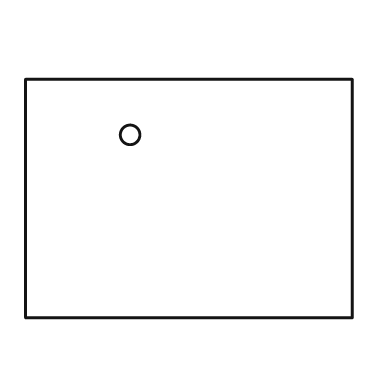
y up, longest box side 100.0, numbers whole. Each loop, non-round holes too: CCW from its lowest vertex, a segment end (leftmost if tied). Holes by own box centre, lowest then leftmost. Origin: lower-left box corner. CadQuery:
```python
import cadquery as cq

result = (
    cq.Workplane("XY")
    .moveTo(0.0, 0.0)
    .lineTo(100.0, 0.0)
    .lineTo(100.0, 73.0)
    .lineTo(0.0, 73.0)
    .close()
    .moveTo(32.0, 56.0)
    .circle(3.0)
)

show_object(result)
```